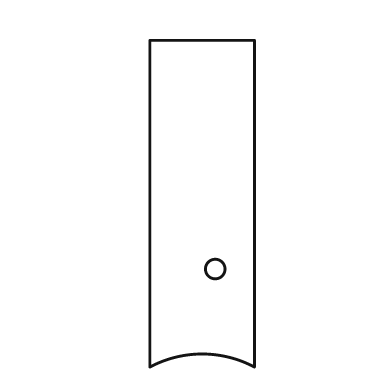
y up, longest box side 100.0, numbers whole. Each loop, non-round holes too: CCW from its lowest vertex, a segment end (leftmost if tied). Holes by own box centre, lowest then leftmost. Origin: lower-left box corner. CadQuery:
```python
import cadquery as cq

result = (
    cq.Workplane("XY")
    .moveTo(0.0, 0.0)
    .threePointArc((16.0, 4.0), (32.0, 0.0))
    .lineTo(32.0, 100.0)
    .lineTo(0.0, 100.0)
    .close()
    .moveTo(20.0, 30.0)
    .circle(3.0)
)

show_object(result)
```